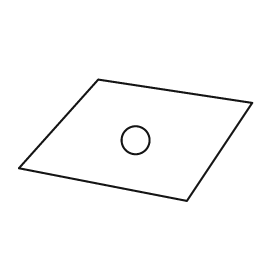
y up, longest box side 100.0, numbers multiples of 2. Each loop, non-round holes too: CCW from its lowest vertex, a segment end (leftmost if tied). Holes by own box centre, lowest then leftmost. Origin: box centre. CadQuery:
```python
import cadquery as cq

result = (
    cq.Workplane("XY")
    .moveTo(22.0, -26.0)
    .lineTo(50.0, 16.0)
    .lineTo(-16.0, 26.0)
    .lineTo(-50.0, -12.0)
    .close()
    .moveTo(0.0, 0.0)
    .circle(6.0)
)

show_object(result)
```